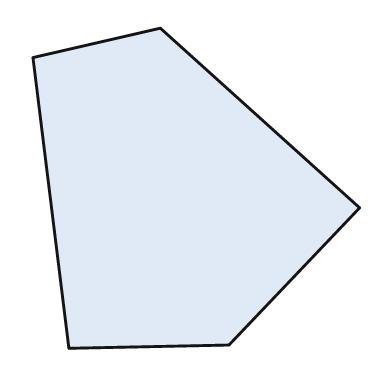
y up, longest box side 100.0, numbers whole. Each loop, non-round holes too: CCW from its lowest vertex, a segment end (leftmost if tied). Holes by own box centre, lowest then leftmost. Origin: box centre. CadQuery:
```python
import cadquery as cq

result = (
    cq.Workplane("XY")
    .moveTo(-39.0, -49.0)
    .lineTo(10.0, -48.0)
    .lineTo(50.0, -6.0)
    .lineTo(-11.0, 49.0)
    .lineTo(-50.0, 40.0)
    .close()
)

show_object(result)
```